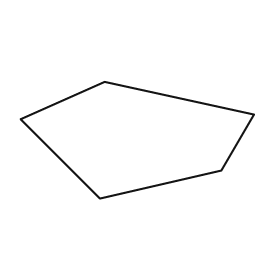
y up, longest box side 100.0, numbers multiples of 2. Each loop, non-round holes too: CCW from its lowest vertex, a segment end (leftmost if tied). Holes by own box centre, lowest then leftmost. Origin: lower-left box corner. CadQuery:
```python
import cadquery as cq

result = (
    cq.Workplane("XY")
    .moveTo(34.0, 0.0)
    .lineTo(86.0, 12.0)
    .lineTo(100.0, 36.0)
    .lineTo(36.0, 50.0)
    .lineTo(0.0, 34.0)
    .close()
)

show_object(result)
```